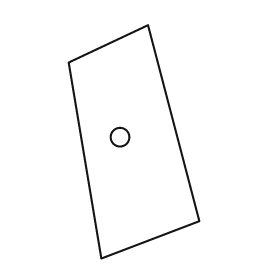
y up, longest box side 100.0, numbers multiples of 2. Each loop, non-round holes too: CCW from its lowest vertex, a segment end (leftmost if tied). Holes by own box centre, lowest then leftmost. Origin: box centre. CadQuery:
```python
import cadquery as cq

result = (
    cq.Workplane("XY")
    .moveTo(-14.0, -50.0)
    .lineTo(28.0, -34.0)
    .lineTo(6.0, 50.0)
    .lineTo(-28.0, 34.0)
    .close()
    .moveTo(-6.0, 2.0)
    .circle(4.0)
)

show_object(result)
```